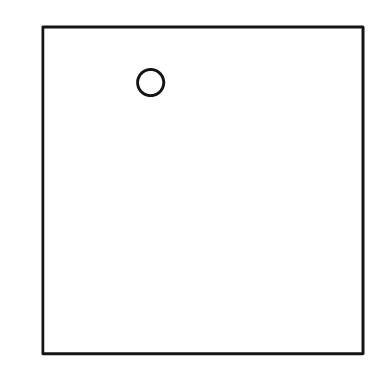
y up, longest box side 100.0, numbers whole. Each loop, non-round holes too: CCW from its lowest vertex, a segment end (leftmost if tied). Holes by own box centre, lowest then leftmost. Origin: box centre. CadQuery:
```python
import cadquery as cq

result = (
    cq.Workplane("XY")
    .moveTo(-49.0, -50.0)
    .lineTo(49.0, -50.0)
    .lineTo(49.0, 50.0)
    .lineTo(-49.0, 50.0)
    .close()
    .moveTo(-16.0, 33.0)
    .circle(4.0)
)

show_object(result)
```